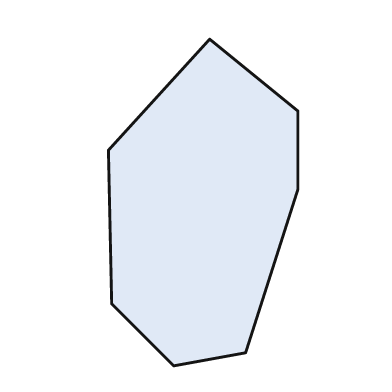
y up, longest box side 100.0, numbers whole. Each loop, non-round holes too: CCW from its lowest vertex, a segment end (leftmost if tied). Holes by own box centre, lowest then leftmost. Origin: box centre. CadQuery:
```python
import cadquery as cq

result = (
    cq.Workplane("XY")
    .moveTo(-9.0, -50.0)
    .lineTo(13.0, -46.0)
    .lineTo(29.0, 4.0)
    .lineTo(29.0, 28.0)
    .lineTo(2.0, 50.0)
    .lineTo(-29.0, 16.0)
    .lineTo(-28.0, -31.0)
    .close()
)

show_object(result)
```